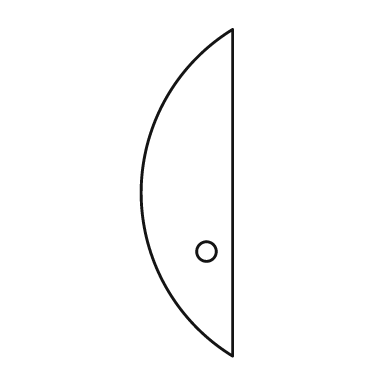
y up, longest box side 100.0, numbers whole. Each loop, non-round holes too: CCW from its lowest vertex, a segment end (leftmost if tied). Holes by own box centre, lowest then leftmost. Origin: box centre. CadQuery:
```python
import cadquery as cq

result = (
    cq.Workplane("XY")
    .moveTo(14.0, -50.0)
    .lineTo(14.0, 50.0)
    .threePointArc((-14.0, 0.0), (14.0, -50.0))
    .close()
    .moveTo(6.0, -18.0)
    .circle(3.0)
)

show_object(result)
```